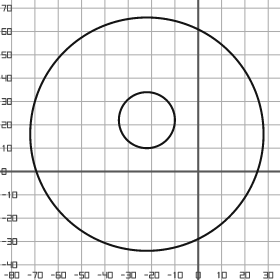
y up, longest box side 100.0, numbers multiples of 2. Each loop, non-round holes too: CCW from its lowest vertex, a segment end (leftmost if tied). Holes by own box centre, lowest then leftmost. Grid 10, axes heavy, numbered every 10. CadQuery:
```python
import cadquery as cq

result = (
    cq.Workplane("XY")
    .moveTo(-22.0, 16.0)
    .circle(50.0)
    .moveTo(-22.0, 22.0)
    .circle(12.0)
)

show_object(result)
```